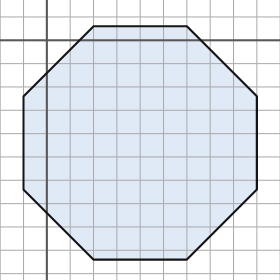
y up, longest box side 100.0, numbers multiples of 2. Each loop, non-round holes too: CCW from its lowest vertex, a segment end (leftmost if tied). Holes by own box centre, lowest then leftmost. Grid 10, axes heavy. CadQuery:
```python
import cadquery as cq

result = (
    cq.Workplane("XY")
    .moveTo(20.0, -94.0)
    .lineTo(60.0, -94.0)
    .lineTo(90.0, -64.0)
    .lineTo(90.0, -24.0)
    .lineTo(60.0, 6.0)
    .lineTo(20.0, 6.0)
    .lineTo(-10.0, -24.0)
    .lineTo(-10.0, -64.0)
    .close()
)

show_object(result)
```